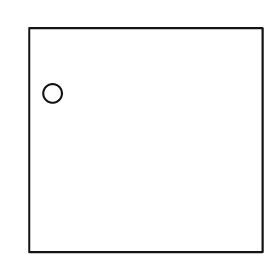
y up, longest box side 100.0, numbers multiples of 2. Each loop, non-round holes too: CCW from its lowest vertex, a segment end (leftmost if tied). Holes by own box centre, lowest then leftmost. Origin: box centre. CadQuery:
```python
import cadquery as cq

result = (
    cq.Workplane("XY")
    .moveTo(-50.0, -48.0)
    .lineTo(50.0, -48.0)
    .lineTo(50.0, 48.0)
    .lineTo(-50.0, 48.0)
    .close()
    .moveTo(-40.0, 20.0)
    .circle(4.0)
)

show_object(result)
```